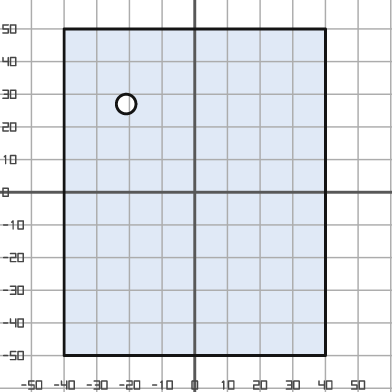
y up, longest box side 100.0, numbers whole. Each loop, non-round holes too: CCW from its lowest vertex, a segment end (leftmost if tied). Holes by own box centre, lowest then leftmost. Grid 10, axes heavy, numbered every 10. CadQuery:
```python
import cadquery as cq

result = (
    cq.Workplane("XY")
    .moveTo(-40.0, -50.0)
    .lineTo(40.0, -50.0)
    .lineTo(40.0, 50.0)
    .lineTo(-40.0, 50.0)
    .close()
    .moveTo(-21.0, 27.0)
    .circle(3.0)
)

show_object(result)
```